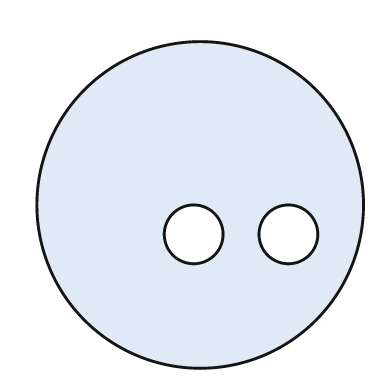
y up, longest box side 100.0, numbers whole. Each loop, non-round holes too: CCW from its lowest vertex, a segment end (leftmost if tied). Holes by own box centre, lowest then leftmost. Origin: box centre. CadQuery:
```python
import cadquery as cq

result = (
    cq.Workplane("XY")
    .moveTo(0.0, 0.0)
    .circle(50.0)
    .moveTo(-2.0, -9.0)
    .circle(9.0)
    .moveTo(27.0, -9.0)
    .circle(9.0)
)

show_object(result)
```